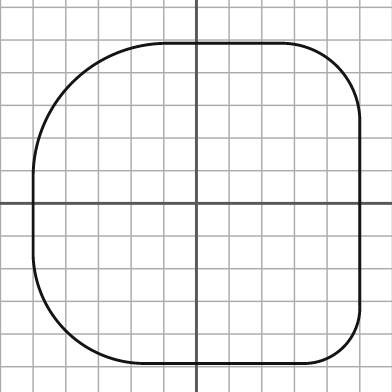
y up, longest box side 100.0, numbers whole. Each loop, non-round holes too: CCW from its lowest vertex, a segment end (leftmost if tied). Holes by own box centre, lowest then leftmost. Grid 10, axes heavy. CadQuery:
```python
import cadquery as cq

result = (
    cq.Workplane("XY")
    .moveTo(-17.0, -49.0)
    .lineTo(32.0, -49.0)
    .threePointArc((45.0, -44.0), (50.0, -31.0))
    .lineTo(50.0, 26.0)
    .threePointArc((43.0, 42.0), (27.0, 49.0))
    .lineTo(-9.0, 49.0)
    .threePointArc((-38.0, 37.0), (-50.0, 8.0))
    .lineTo(-50.0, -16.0)
    .threePointArc((-40.0, -39.0), (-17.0, -49.0))
    .close()
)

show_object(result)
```